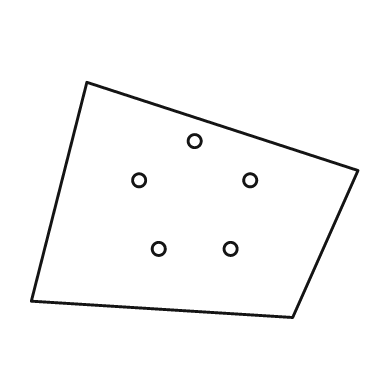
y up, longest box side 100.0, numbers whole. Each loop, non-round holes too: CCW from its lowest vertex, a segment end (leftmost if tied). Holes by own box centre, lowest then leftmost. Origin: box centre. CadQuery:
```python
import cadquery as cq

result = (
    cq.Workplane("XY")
    .moveTo(30.0, -36.0)
    .lineTo(50.0, 9.0)
    .lineTo(-33.0, 36.0)
    .lineTo(-50.0, -31.0)
    .close()
    .moveTo(-11.0, -15.0)
    .circle(2.0)
    .moveTo(11.0, -15.0)
    .circle(2.0)
    .moveTo(-17.0, 6.0)
    .circle(2.0)
    .moveTo(17.0, 6.0)
    .circle(2.0)
    .moveTo(0.0, 18.0)
    .circle(2.0)
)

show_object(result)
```